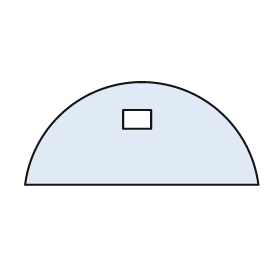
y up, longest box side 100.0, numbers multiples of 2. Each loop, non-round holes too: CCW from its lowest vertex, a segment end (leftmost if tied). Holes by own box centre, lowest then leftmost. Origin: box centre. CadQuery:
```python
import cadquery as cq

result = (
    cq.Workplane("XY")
    .moveTo(-50.0, -22.0)
    .lineTo(50.0, -22.0)
    .threePointArc((0.0, 22.0), (-50.0, -22.0))
    .close()
    .moveTo(-8.0, 2.0)
    .lineTo(4.0, 2.0)
    .lineTo(4.0, 10.0)
    .lineTo(-8.0, 10.0)
    .close()
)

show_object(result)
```